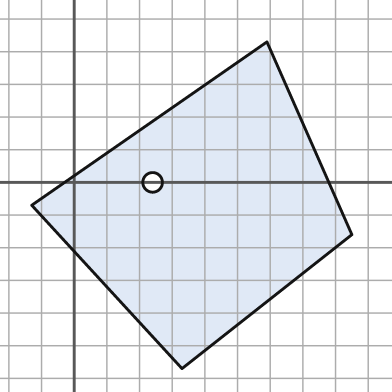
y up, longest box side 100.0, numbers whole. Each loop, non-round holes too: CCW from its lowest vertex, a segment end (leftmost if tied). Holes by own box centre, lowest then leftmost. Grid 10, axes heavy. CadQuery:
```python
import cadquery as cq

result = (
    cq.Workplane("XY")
    .moveTo(33.0, -57.0)
    .lineTo(85.0, -16.0)
    .lineTo(59.0, 43.0)
    .lineTo(-13.0, -7.0)
    .close()
    .moveTo(24.0, 0.0)
    .circle(3.0)
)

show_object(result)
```